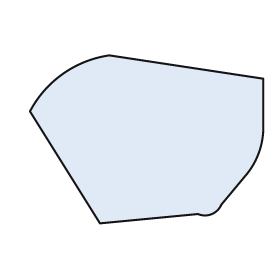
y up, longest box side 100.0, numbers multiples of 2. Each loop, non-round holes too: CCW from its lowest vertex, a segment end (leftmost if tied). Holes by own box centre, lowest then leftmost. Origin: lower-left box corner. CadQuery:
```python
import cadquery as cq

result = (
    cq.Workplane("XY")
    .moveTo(30.0, 0.0)
    .lineTo(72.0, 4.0)
    .threePointArc((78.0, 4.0), (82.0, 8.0))
    .lineTo(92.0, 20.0)
    .threePointArc((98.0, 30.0), (100.0, 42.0))
    .lineTo(100.0, 62.0)
    .lineTo(34.0, 72.0)
    .threePointArc((14.0, 64.0), (0.0, 48.0))
    .close()
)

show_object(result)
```